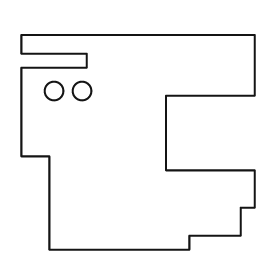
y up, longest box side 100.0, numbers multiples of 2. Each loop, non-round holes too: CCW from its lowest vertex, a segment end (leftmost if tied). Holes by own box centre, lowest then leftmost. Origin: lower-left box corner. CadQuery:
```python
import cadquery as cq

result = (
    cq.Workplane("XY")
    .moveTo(12.0, 0.0)
    .lineTo(72.0, 0.0)
    .lineTo(72.0, 6.0)
    .lineTo(94.0, 6.0)
    .lineTo(94.0, 18.0)
    .lineTo(100.0, 18.0)
    .lineTo(100.0, 34.0)
    .lineTo(62.0, 34.0)
    .lineTo(62.0, 66.0)
    .lineTo(100.0, 66.0)
    .lineTo(100.0, 92.0)
    .lineTo(0.0, 92.0)
    .lineTo(0.0, 84.0)
    .lineTo(28.0, 84.0)
    .lineTo(28.0, 78.0)
    .lineTo(0.0, 78.0)
    .lineTo(0.0, 40.0)
    .lineTo(12.0, 40.0)
    .close()
    .moveTo(14.0, 68.0)
    .circle(4.0)
    .moveTo(26.0, 68.0)
    .circle(4.0)
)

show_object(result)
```